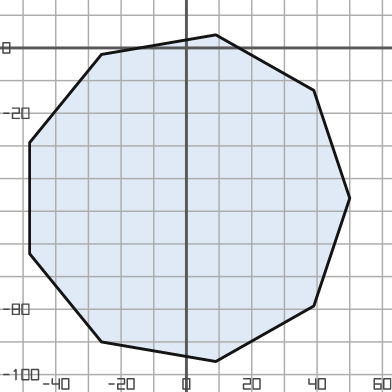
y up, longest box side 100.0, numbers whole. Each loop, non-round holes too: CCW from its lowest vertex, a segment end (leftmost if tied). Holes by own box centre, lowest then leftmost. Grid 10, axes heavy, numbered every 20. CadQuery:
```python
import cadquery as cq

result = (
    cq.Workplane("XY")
    .moveTo(9.0, -96.0)
    .lineTo(39.0, -79.0)
    .lineTo(50.0, -46.0)
    .lineTo(39.0, -13.0)
    .lineTo(9.0, 4.0)
    .lineTo(-26.0, -2.0)
    .lineTo(-48.0, -29.0)
    .lineTo(-48.0, -63.0)
    .lineTo(-26.0, -90.0)
    .close()
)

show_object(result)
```